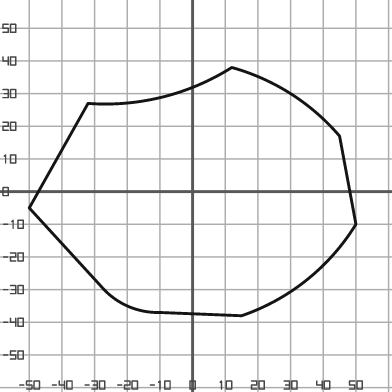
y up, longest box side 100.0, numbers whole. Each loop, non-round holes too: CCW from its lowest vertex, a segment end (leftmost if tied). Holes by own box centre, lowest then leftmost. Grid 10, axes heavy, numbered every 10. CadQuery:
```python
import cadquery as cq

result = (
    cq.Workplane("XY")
    .moveTo(15.0, -38.0)
    .threePointArc((35.0, -27.0), (50.0, -10.0))
    .lineTo(45.0, 17.0)
    .threePointArc((30.0, 30.0), (12.0, 38.0))
    .threePointArc((-9.0, 29.0), (-32.0, 27.0))
    .lineTo(-50.0, -5.0)
    .lineTo(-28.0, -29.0)
    .threePointArc((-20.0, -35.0), (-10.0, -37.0))
    .close()
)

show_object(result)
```